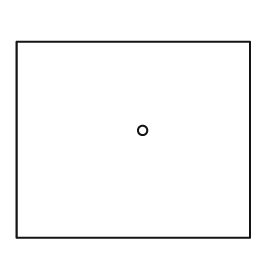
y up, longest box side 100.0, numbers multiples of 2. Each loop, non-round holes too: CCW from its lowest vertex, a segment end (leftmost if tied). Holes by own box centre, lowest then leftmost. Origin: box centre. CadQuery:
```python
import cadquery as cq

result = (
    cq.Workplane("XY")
    .moveTo(-50.0, -42.0)
    .lineTo(50.0, -42.0)
    .lineTo(50.0, 42.0)
    .lineTo(-50.0, 42.0)
    .close()
    .moveTo(4.0, 4.0)
    .circle(2.0)
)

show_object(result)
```